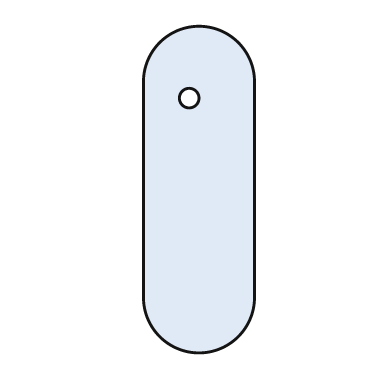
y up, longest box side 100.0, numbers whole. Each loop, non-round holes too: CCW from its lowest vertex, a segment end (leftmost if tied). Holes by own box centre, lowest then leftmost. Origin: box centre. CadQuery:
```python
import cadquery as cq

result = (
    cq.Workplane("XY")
    .moveTo(-17.0, -33.0)
    .threePointArc((0.0, -50.0), (17.0, -33.0))
    .lineTo(17.0, 33.0)
    .threePointArc((0.0, 50.0), (-17.0, 33.0))
    .close()
    .moveTo(-3.0, 28.0)
    .circle(3.0)
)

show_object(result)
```